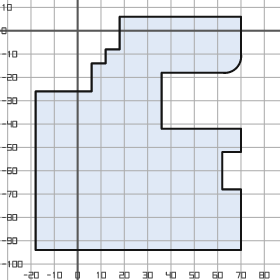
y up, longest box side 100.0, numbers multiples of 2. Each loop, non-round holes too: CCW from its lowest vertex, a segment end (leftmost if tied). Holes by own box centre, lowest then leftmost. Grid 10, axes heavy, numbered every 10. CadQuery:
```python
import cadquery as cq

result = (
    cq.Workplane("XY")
    .moveTo(-18.0, -94.0)
    .lineTo(70.0, -94.0)
    .lineTo(70.0, -68.0)
    .lineTo(62.0, -68.0)
    .lineTo(62.0, -52.0)
    .lineTo(70.0, -52.0)
    .lineTo(70.0, -42.0)
    .lineTo(36.0, -42.0)
    .lineTo(36.0, -18.0)
    .lineTo(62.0, -18.0)
    .threePointArc((68.0, -16.0), (70.0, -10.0))
    .lineTo(70.0, 6.0)
    .lineTo(18.0, 6.0)
    .lineTo(18.0, -8.0)
    .lineTo(12.0, -8.0)
    .lineTo(12.0, -14.0)
    .lineTo(6.0, -14.0)
    .lineTo(6.0, -26.0)
    .lineTo(-18.0, -26.0)
    .close()
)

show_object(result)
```